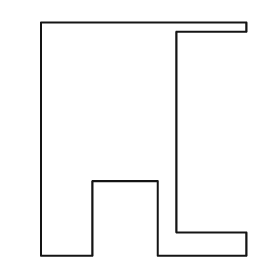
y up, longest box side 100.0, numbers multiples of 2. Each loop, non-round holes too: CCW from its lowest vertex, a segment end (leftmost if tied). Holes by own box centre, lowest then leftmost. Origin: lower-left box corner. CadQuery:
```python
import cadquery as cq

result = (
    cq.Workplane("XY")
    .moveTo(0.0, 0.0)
    .lineTo(22.0, 0.0)
    .lineTo(22.0, 32.0)
    .lineTo(50.0, 32.0)
    .lineTo(50.0, 0.0)
    .lineTo(88.0, 0.0)
    .lineTo(88.0, 10.0)
    .lineTo(58.0, 10.0)
    .lineTo(58.0, 96.0)
    .lineTo(88.0, 96.0)
    .lineTo(88.0, 100.0)
    .lineTo(0.0, 100.0)
    .close()
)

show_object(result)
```